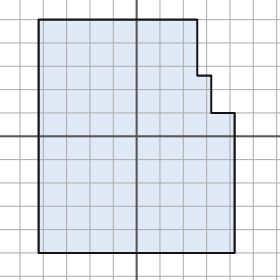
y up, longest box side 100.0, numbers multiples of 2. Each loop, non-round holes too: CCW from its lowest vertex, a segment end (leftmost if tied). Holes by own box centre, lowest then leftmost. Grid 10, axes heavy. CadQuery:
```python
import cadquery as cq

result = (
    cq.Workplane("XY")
    .moveTo(-42.0, -50.0)
    .lineTo(42.0, -50.0)
    .lineTo(42.0, 10.0)
    .lineTo(32.0, 10.0)
    .lineTo(32.0, 26.0)
    .lineTo(26.0, 26.0)
    .lineTo(26.0, 50.0)
    .lineTo(-42.0, 50.0)
    .close()
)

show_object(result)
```